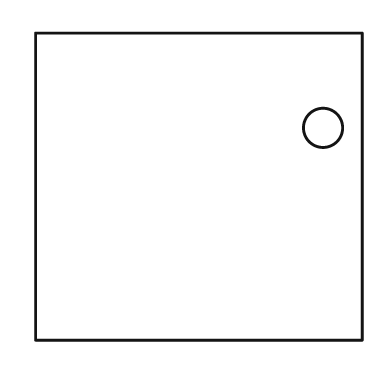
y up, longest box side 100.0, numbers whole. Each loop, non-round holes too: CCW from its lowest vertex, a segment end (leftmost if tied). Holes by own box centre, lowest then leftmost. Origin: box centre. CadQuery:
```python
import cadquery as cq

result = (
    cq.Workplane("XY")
    .moveTo(-50.0, -47.0)
    .lineTo(50.0, -47.0)
    .lineTo(50.0, 47.0)
    .lineTo(-50.0, 47.0)
    .close()
    .moveTo(38.0, 18.0)
    .circle(6.0)
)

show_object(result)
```